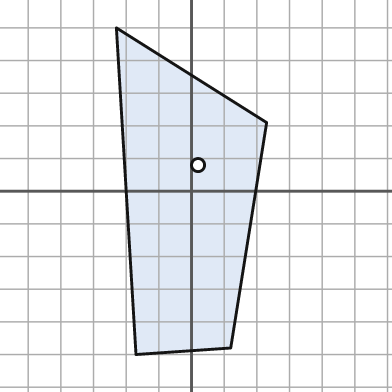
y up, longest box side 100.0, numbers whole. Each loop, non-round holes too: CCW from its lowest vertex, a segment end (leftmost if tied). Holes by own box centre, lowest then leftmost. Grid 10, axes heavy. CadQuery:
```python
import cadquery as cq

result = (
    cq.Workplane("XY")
    .moveTo(-17.0, -50.0)
    .lineTo(12.0, -48.0)
    .lineTo(23.0, 21.0)
    .lineTo(-23.0, 50.0)
    .close()
    .moveTo(2.0, 8.0)
    .circle(2.0)
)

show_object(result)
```